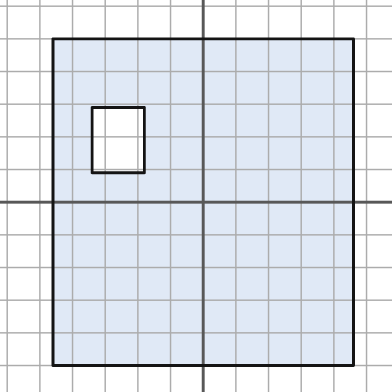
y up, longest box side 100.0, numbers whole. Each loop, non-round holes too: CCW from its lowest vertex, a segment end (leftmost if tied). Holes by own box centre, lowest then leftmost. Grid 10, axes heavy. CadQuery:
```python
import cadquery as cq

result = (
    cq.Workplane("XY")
    .moveTo(-46.0, -50.0)
    .lineTo(46.0, -50.0)
    .lineTo(46.0, 50.0)
    .lineTo(-46.0, 50.0)
    .close()
    .moveTo(-34.0, 9.0)
    .lineTo(-18.0, 9.0)
    .lineTo(-18.0, 29.0)
    .lineTo(-34.0, 29.0)
    .close()
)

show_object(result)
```